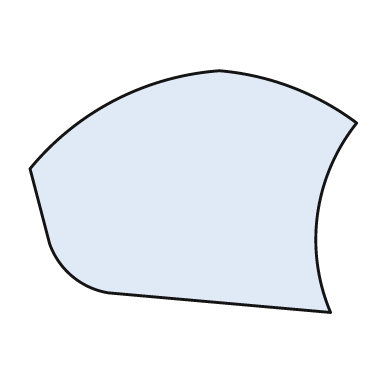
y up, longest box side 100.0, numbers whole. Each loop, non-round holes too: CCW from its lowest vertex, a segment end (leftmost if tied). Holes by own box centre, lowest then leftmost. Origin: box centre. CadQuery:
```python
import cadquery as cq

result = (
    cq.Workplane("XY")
    .moveTo(42.0, -37.0)
    .threePointArc((38.0, -7.0), (50.0, 21.0))
    .threePointArc((30.0, 32.0), (8.0, 37.0))
    .threePointArc((-24.0, 28.0), (-50.0, 7.0))
    .lineTo(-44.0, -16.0)
    .threePointArc((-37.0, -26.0), (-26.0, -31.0))
    .close()
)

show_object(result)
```